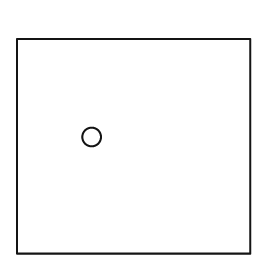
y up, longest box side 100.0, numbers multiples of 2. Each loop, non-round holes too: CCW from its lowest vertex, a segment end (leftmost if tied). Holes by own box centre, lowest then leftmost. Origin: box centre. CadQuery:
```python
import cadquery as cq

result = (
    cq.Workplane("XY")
    .moveTo(-50.0, -46.0)
    .lineTo(50.0, -46.0)
    .lineTo(50.0, 46.0)
    .lineTo(-50.0, 46.0)
    .close()
    .moveTo(-18.0, 4.0)
    .circle(4.0)
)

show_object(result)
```